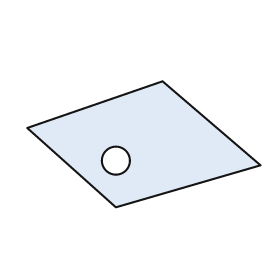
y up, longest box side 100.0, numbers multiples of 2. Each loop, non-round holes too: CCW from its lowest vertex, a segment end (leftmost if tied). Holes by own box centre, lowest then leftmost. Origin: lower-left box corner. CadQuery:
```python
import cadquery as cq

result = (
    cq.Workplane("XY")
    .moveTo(38.0, 0.0)
    .lineTo(100.0, 18.0)
    .lineTo(58.0, 54.0)
    .lineTo(0.0, 34.0)
    .close()
    .moveTo(38.0, 20.0)
    .circle(6.0)
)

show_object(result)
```